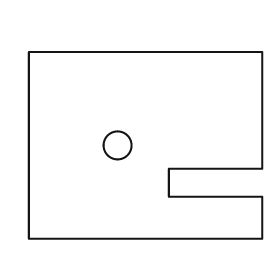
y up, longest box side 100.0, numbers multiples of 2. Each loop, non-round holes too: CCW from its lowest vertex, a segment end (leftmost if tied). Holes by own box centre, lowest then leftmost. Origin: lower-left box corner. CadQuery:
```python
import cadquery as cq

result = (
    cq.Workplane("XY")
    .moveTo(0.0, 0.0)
    .lineTo(100.0, 0.0)
    .lineTo(100.0, 18.0)
    .lineTo(60.0, 18.0)
    .lineTo(60.0, 30.0)
    .lineTo(100.0, 30.0)
    .lineTo(100.0, 80.0)
    .lineTo(0.0, 80.0)
    .close()
    .moveTo(38.0, 40.0)
    .circle(6.0)
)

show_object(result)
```